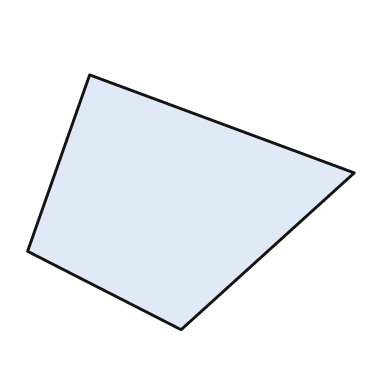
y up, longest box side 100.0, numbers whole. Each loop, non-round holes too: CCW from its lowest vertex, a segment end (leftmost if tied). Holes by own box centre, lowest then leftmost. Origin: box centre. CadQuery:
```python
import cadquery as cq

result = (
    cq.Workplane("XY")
    .moveTo(-3.0, -39.0)
    .lineTo(50.0, 9.0)
    .lineTo(-31.0, 39.0)
    .lineTo(-50.0, -15.0)
    .close()
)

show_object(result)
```